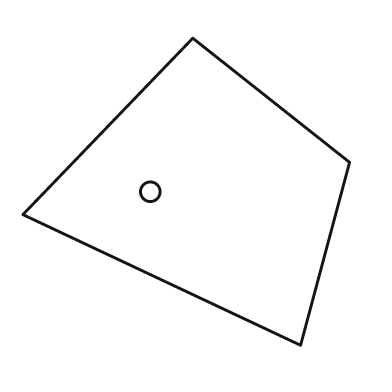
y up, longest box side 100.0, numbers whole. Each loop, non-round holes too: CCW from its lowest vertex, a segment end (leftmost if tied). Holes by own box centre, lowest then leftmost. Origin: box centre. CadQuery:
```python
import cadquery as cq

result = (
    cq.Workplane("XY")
    .moveTo(35.0, -47.0)
    .lineTo(50.0, 9.0)
    .lineTo(2.0, 47.0)
    .lineTo(-50.0, -7.0)
    .close()
    .moveTo(-11.0, 0.0)
    .circle(3.0)
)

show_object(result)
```